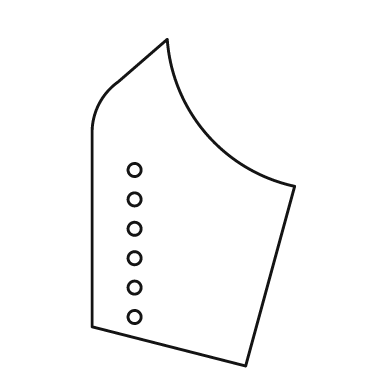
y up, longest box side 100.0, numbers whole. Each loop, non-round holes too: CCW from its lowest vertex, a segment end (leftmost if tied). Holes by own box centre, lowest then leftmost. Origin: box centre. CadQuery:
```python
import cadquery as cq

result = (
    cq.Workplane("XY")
    .moveTo(16.0, -50.0)
    .lineTo(31.0, 5.0)
    .threePointArc((4.0, 21.0), (-8.0, 50.0))
    .lineTo(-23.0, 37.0)
    .threePointArc((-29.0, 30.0), (-31.0, 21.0))
    .lineTo(-31.0, -38.0)
    .close()
    .moveTo(-18.0, -35.0)
    .circle(2.0)
    .moveTo(-18.0, -26.0)
    .circle(2.0)
    .moveTo(-18.0, -17.0)
    .circle(2.0)
    .moveTo(-18.0, -8.0)
    .circle(2.0)
    .moveTo(-18.0, 1.0)
    .circle(2.0)
    .moveTo(-18.0, 10.0)
    .circle(2.0)
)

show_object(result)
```